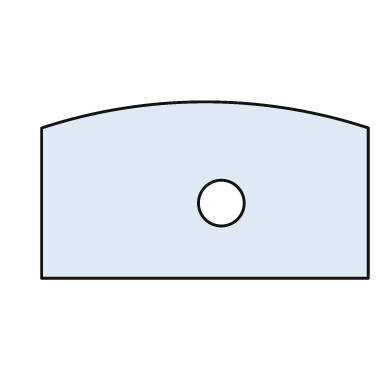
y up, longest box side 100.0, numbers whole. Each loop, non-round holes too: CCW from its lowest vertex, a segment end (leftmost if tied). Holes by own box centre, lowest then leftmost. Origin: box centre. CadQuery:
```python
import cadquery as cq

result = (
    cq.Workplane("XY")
    .moveTo(-50.0, -27.0)
    .lineTo(50.0, -27.0)
    .lineTo(50.0, 19.0)
    .threePointArc((0.0, 27.0), (-50.0, 19.0))
    .close()
    .moveTo(5.0, -4.0)
    .circle(7.0)
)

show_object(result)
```